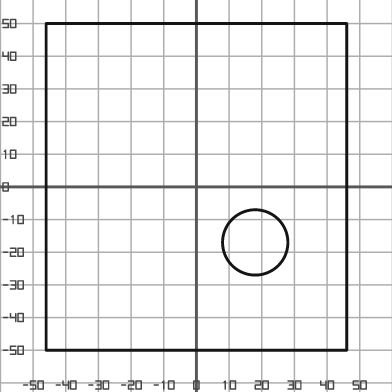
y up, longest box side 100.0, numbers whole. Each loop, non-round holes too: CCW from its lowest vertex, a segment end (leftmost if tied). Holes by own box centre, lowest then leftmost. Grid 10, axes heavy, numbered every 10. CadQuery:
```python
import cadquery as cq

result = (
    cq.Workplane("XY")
    .moveTo(-46.0, -50.0)
    .lineTo(46.0, -50.0)
    .lineTo(46.0, 50.0)
    .lineTo(-46.0, 50.0)
    .close()
    .moveTo(18.0, -17.0)
    .circle(10.0)
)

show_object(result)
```